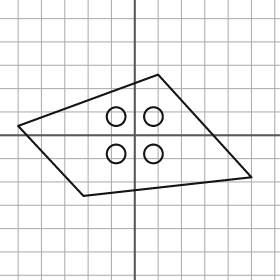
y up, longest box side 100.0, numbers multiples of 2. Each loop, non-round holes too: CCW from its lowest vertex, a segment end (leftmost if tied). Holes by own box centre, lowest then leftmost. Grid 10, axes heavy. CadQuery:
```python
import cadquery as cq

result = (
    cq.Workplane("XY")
    .moveTo(-22.0, -26.0)
    .lineTo(50.0, -18.0)
    .lineTo(10.0, 26.0)
    .lineTo(-50.0, 4.0)
    .close()
    .moveTo(-8.0, -8.0)
    .circle(4.0)
    .moveTo(8.0, -8.0)
    .circle(4.0)
    .moveTo(-8.0, 8.0)
    .circle(4.0)
    .moveTo(8.0, 8.0)
    .circle(4.0)
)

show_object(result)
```